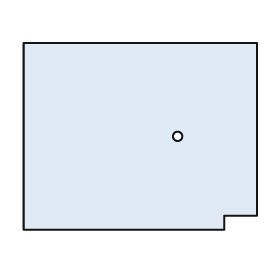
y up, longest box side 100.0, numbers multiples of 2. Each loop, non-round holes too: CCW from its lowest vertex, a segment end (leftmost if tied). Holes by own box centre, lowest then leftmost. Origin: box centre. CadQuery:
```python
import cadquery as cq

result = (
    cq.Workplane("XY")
    .moveTo(-50.0, -40.0)
    .lineTo(36.0, -40.0)
    .lineTo(36.0, -34.0)
    .lineTo(50.0, -34.0)
    .lineTo(50.0, 40.0)
    .lineTo(-50.0, 40.0)
    .close()
    .moveTo(16.0, 0.0)
    .circle(2.0)
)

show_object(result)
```